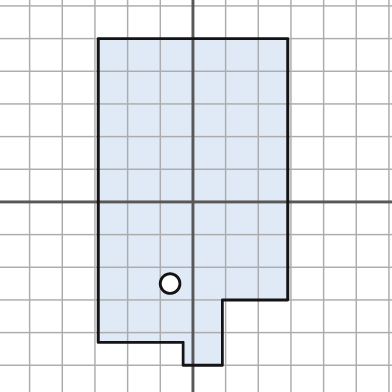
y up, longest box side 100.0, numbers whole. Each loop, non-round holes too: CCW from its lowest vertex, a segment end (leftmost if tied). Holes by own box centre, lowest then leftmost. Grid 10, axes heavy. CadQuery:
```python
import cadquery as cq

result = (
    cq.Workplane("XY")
    .moveTo(-3.0, -50.0)
    .lineTo(9.0, -50.0)
    .lineTo(9.0, -30.0)
    .lineTo(29.0, -30.0)
    .lineTo(29.0, 50.0)
    .lineTo(-29.0, 50.0)
    .lineTo(-29.0, -43.0)
    .lineTo(-3.0, -43.0)
    .close()
    .moveTo(-7.0, -25.0)
    .circle(3.0)
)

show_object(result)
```